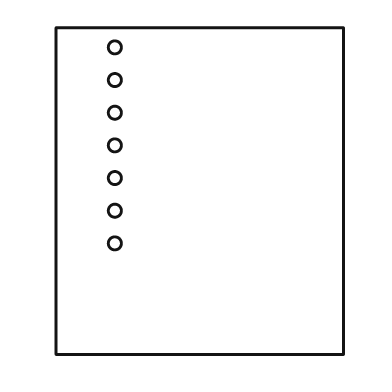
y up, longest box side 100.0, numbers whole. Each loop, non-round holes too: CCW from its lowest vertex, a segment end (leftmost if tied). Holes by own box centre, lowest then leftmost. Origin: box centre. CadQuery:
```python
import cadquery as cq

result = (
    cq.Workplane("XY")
    .moveTo(-44.0, -50.0)
    .lineTo(44.0, -50.0)
    .lineTo(44.0, 50.0)
    .lineTo(-44.0, 50.0)
    .close()
    .moveTo(-26.0, -16.0)
    .circle(2.0)
    .moveTo(-26.0, -6.0)
    .circle(2.0)
    .moveTo(-26.0, 4.0)
    .circle(2.0)
    .moveTo(-26.0, 14.0)
    .circle(2.0)
    .moveTo(-26.0, 24.0)
    .circle(2.0)
    .moveTo(-26.0, 34.0)
    .circle(2.0)
    .moveTo(-26.0, 44.0)
    .circle(2.0)
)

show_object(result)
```